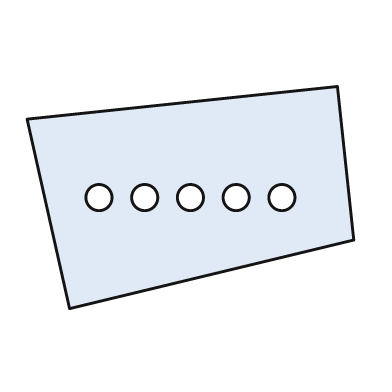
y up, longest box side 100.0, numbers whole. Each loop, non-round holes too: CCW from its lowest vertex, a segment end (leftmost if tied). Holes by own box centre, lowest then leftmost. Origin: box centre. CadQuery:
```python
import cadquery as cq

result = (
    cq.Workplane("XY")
    .moveTo(-37.0, -34.0)
    .lineTo(50.0, -13.0)
    .lineTo(45.0, 34.0)
    .lineTo(-50.0, 24.0)
    .close()
    .moveTo(-28.0, 0.0)
    .circle(4.0)
    .moveTo(-14.0, 0.0)
    .circle(4.0)
    .moveTo(0.0, 0.0)
    .circle(4.0)
    .moveTo(14.0, 0.0)
    .circle(4.0)
    .moveTo(28.0, 0.0)
    .circle(4.0)
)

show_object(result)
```